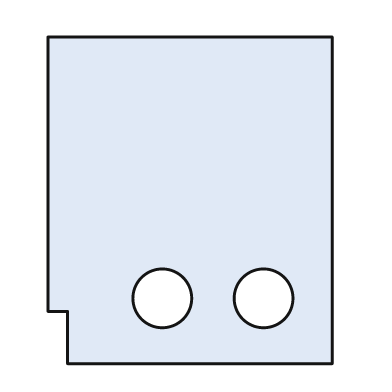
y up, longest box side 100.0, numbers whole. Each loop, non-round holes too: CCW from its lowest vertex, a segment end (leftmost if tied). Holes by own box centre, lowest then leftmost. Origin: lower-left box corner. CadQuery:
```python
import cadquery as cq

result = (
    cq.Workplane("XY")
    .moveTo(6.0, 0.0)
    .lineTo(87.0, 0.0)
    .lineTo(87.0, 100.0)
    .lineTo(0.0, 100.0)
    .lineTo(0.0, 16.0)
    .lineTo(6.0, 16.0)
    .close()
    .moveTo(35.0, 20.0)
    .circle(9.0)
    .moveTo(66.0, 20.0)
    .circle(9.0)
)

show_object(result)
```